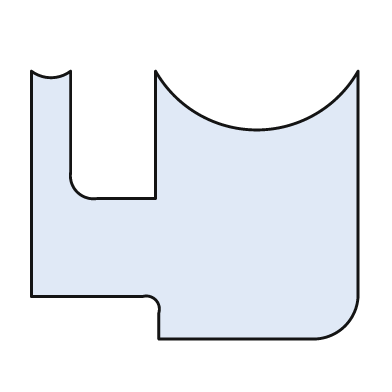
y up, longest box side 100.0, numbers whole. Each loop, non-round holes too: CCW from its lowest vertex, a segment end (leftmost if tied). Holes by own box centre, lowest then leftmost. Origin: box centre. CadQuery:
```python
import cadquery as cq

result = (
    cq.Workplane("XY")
    .moveTo(-11.0, -41.0)
    .lineTo(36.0, -41.0)
    .threePointArc((46.0, -37.0), (50.0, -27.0))
    .lineTo(50.0, 41.0)
    .threePointArc((19.0, 23.0), (-12.0, 41.0))
    .lineTo(-12.0, 2.0)
    .lineTo(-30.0, 2.0)
    .threePointArc((-36.0, 4.0), (-38.0, 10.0))
    .lineTo(-38.0, 41.0)
    .threePointArc((-44.0, 39.0), (-50.0, 41.0))
    .lineTo(-50.0, -28.0)
    .lineTo(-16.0, -28.0)
    .threePointArc((-12.0, -29.0), (-11.0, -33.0))
    .close()
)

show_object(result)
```